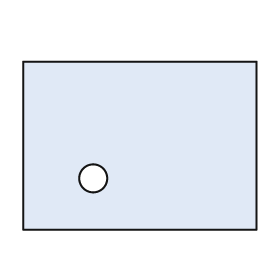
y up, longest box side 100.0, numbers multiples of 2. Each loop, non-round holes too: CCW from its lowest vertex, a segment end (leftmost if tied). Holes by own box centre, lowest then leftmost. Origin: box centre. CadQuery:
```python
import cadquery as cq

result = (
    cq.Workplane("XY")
    .moveTo(-50.0, -36.0)
    .lineTo(50.0, -36.0)
    .lineTo(50.0, 36.0)
    .lineTo(-50.0, 36.0)
    .close()
    .moveTo(-20.0, -14.0)
    .circle(6.0)
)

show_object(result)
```